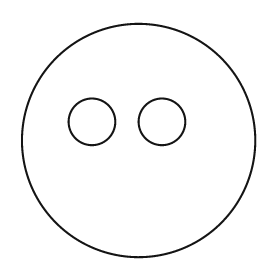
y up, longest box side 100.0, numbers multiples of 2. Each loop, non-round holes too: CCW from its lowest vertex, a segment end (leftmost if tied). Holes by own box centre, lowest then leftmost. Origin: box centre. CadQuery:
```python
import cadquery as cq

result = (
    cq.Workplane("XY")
    .moveTo(0.0, 0.0)
    .circle(50.0)
    .moveTo(-20.0, 8.0)
    .circle(10.0)
    .moveTo(10.0, 8.0)
    .circle(10.0)
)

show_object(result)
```